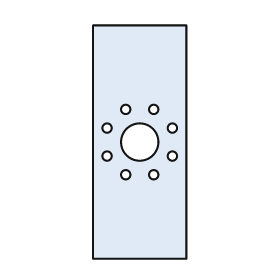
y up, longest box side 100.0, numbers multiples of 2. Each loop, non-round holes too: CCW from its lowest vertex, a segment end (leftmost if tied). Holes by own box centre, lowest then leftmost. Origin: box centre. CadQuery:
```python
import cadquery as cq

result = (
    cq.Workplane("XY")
    .moveTo(-20.0, -50.0)
    .lineTo(20.0, -50.0)
    .lineTo(20.0, 50.0)
    .lineTo(-20.0, 50.0)
    .close()
    .moveTo(-6.0, -14.0)
    .circle(2.0)
    .moveTo(6.0, -14.0)
    .circle(2.0)
    .moveTo(-14.0, -6.0)
    .circle(2.0)
    .moveTo(14.0, -6.0)
    .circle(2.0)
    .moveTo(0.0, 0.0)
    .circle(8.0)
    .moveTo(-14.0, 6.0)
    .circle(2.0)
    .moveTo(14.0, 6.0)
    .circle(2.0)
    .moveTo(-6.0, 14.0)
    .circle(2.0)
    .moveTo(6.0, 14.0)
    .circle(2.0)
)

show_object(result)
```